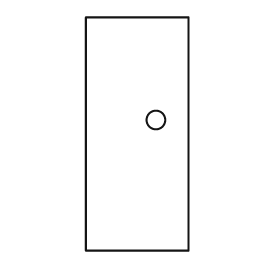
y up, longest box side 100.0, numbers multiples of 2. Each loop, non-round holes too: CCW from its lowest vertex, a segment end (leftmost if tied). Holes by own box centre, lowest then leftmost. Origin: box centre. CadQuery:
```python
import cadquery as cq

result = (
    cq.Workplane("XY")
    .moveTo(-22.0, -50.0)
    .lineTo(22.0, -50.0)
    .lineTo(22.0, 50.0)
    .lineTo(-22.0, 50.0)
    .close()
    .moveTo(8.0, 6.0)
    .circle(4.0)
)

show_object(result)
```